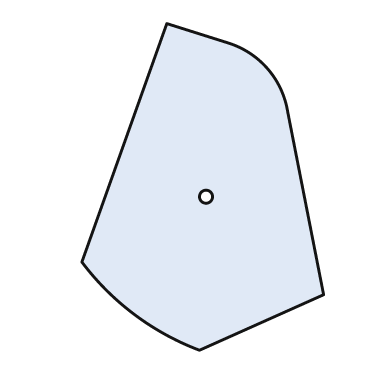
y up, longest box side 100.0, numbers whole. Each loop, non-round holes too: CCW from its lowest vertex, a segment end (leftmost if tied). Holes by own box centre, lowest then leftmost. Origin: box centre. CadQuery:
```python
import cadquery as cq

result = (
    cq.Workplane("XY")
    .moveTo(-1.0, -50.0)
    .lineTo(37.0, -33.0)
    .lineTo(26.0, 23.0)
    .threePointArc((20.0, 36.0), (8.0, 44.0))
    .lineTo(-11.0, 50.0)
    .lineTo(-37.0, -23.0)
    .threePointArc((-21.0, -39.0), (-1.0, -50.0))
    .close()
    .moveTo(1.0, -3.0)
    .circle(2.0)
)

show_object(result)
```